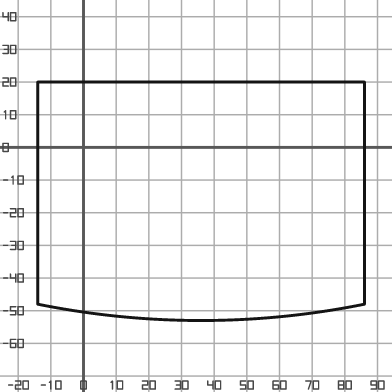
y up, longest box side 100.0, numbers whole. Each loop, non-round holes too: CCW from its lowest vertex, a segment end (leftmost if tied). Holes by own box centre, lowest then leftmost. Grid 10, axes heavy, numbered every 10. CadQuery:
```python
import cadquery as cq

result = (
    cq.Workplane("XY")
    .moveTo(-14.0, -48.0)
    .threePointArc((36.0, -53.0), (86.0, -48.0))
    .lineTo(86.0, 20.0)
    .lineTo(-14.0, 20.0)
    .close()
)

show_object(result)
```